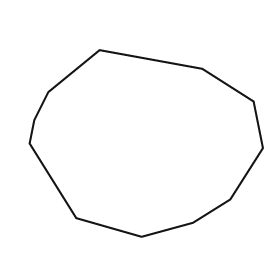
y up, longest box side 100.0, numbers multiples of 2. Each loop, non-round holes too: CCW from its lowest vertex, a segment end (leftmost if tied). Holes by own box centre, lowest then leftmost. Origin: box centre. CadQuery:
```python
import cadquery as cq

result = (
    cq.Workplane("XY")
    .moveTo(-2.0, -40.0)
    .lineTo(20.0, -34.0)
    .lineTo(36.0, -24.0)
    .lineTo(50.0, -2.0)
    .lineTo(46.0, 18.0)
    .lineTo(24.0, 32.0)
    .lineTo(-20.0, 40.0)
    .lineTo(-42.0, 22.0)
    .lineTo(-48.0, 10.0)
    .lineTo(-50.0, 0.0)
    .lineTo(-30.0, -32.0)
    .close()
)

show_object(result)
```